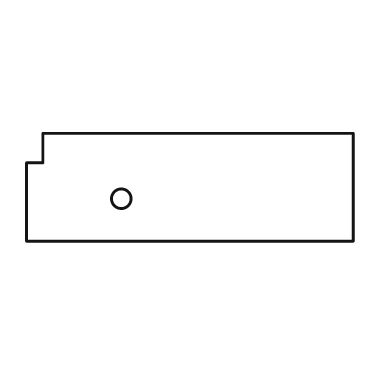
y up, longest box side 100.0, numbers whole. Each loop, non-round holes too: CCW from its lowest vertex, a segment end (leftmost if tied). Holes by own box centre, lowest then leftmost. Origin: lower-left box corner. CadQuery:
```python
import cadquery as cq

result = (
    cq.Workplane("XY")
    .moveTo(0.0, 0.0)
    .lineTo(100.0, 0.0)
    .lineTo(100.0, 33.0)
    .lineTo(5.0, 33.0)
    .lineTo(5.0, 24.0)
    .lineTo(0.0, 24.0)
    .close()
    .moveTo(29.0, 13.0)
    .circle(3.0)
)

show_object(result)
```